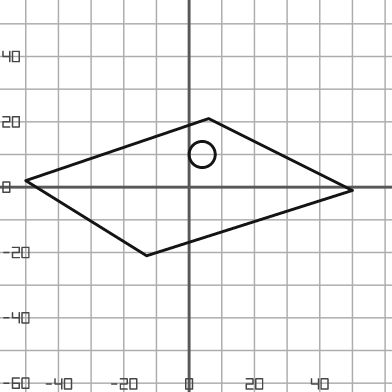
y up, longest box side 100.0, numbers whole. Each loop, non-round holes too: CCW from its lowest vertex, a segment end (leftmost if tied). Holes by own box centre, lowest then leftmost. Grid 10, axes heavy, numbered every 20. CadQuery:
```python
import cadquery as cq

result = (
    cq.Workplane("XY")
    .moveTo(-13.0, -21.0)
    .lineTo(50.0, -1.0)
    .lineTo(6.0, 21.0)
    .lineTo(-50.0, 2.0)
    .close()
    .moveTo(4.0, 10.0)
    .circle(4.0)
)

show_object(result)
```